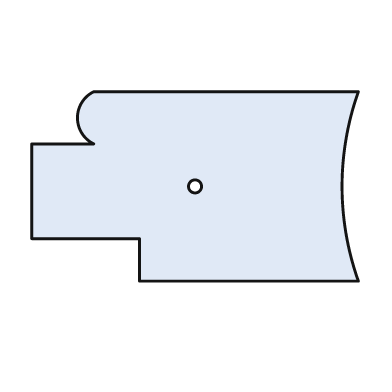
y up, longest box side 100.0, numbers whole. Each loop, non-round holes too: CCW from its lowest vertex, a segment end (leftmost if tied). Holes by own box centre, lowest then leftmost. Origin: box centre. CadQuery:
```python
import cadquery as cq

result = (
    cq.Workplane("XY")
    .moveTo(-17.0, -29.0)
    .lineTo(50.0, -29.0)
    .threePointArc((45.0, 0.0), (50.0, 29.0))
    .lineTo(-31.0, 29.0)
    .threePointArc((-36.0, 21.0), (-31.0, 13.0))
    .lineTo(-50.0, 13.0)
    .lineTo(-50.0, -16.0)
    .lineTo(-17.0, -16.0)
    .close()
    .moveTo(0.0, 0.0)
    .circle(2.0)
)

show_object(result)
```